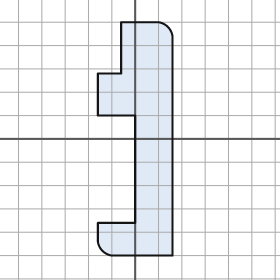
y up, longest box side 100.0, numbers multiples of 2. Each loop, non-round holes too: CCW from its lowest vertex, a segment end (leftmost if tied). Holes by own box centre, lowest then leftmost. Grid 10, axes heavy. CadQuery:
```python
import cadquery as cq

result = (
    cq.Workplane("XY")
    .moveTo(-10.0, -50.0)
    .lineTo(16.0, -50.0)
    .lineTo(16.0, 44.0)
    .threePointArc((14.0, 48.0), (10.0, 50.0))
    .lineTo(-6.0, 50.0)
    .lineTo(-6.0, 28.0)
    .lineTo(-16.0, 28.0)
    .lineTo(-16.0, 10.0)
    .lineTo(0.0, 10.0)
    .lineTo(0.0, -36.0)
    .lineTo(-16.0, -36.0)
    .lineTo(-16.0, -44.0)
    .threePointArc((-14.0, -48.0), (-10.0, -50.0))
    .close()
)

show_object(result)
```